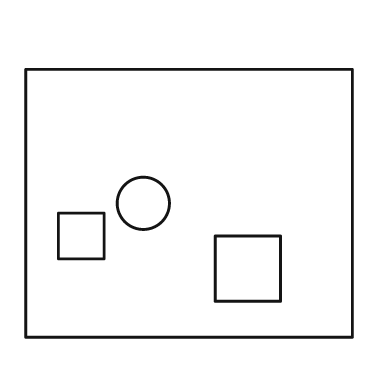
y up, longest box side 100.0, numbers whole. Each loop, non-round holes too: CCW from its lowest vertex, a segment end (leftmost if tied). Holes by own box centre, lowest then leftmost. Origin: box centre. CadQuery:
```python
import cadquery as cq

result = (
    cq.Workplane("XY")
    .moveTo(-50.0, -41.0)
    .lineTo(50.0, -41.0)
    .lineTo(50.0, 41.0)
    .lineTo(-50.0, 41.0)
    .close()
    .moveTo(8.0, -30.0)
    .lineTo(28.0, -30.0)
    .lineTo(28.0, -10.0)
    .lineTo(8.0, -10.0)
    .close()
    .moveTo(-40.0, -17.0)
    .lineTo(-26.0, -17.0)
    .lineTo(-26.0, -3.0)
    .lineTo(-40.0, -3.0)
    .close()
    .moveTo(-14.0, 0.0)
    .circle(8.0)
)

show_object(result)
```